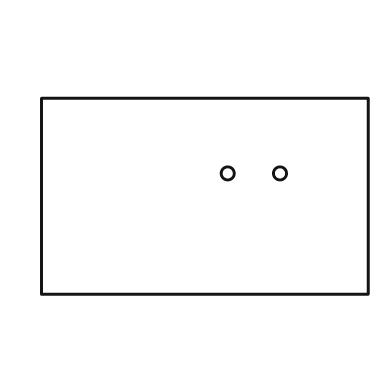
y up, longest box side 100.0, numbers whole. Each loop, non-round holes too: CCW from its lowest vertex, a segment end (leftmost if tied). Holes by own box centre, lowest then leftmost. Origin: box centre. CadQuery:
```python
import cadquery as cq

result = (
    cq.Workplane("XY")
    .moveTo(-50.0, -30.0)
    .lineTo(50.0, -30.0)
    .lineTo(50.0, 30.0)
    .lineTo(-50.0, 30.0)
    .close()
    .moveTo(7.0, 7.0)
    .circle(2.0)
    .moveTo(23.0, 7.0)
    .circle(2.0)
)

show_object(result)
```